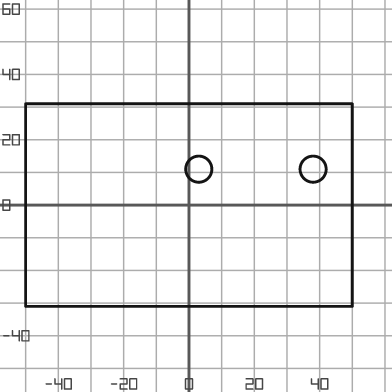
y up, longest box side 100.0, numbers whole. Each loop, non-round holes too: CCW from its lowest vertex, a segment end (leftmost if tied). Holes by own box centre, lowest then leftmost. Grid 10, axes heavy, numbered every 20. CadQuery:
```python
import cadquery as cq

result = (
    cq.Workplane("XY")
    .moveTo(-50.0, -31.0)
    .lineTo(50.0, -31.0)
    .lineTo(50.0, 31.0)
    .lineTo(-50.0, 31.0)
    .close()
    .moveTo(3.0, 11.0)
    .circle(4.0)
    .moveTo(38.0, 11.0)
    .circle(4.0)
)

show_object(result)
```